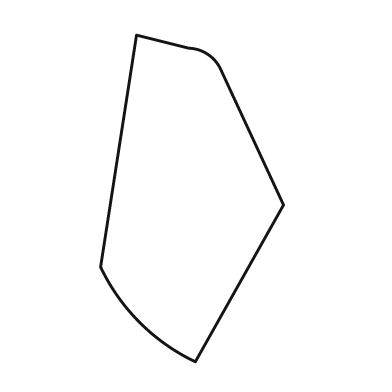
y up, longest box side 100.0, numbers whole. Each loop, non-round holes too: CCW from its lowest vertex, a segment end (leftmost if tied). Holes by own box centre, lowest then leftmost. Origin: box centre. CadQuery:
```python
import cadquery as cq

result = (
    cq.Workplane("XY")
    .moveTo(1.0, -50.0)
    .lineTo(28.0, -2.0)
    .lineTo(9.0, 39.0)
    .threePointArc((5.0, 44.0), (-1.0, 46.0))
    .lineTo(-17.0, 50.0)
    .lineTo(-28.0, -21.0)
    .threePointArc((-16.0, -38.0), (1.0, -50.0))
    .close()
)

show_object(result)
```